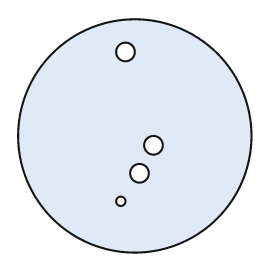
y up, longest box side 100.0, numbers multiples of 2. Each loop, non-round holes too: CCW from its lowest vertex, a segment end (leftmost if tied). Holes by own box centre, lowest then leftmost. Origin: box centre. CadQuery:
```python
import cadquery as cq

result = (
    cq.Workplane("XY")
    .moveTo(0.0, 0.0)
    .circle(50.0)
    .moveTo(-6.0, -28.0)
    .circle(2.0)
    .moveTo(2.0, -16.0)
    .circle(4.0)
    .moveTo(8.0, -4.0)
    .circle(4.0)
    .moveTo(-4.0, 36.0)
    .circle(4.0)
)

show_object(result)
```